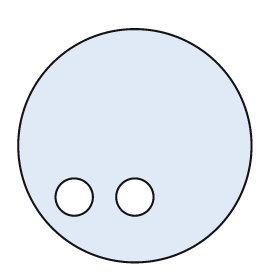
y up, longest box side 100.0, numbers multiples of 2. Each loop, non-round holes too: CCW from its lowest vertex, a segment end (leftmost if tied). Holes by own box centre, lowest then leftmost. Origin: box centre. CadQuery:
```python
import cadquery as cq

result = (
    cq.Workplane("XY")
    .moveTo(0.0, 0.0)
    .circle(50.0)
    .moveTo(-26.0, -22.0)
    .circle(8.0)
    .moveTo(0.0, -22.0)
    .circle(8.0)
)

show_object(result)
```